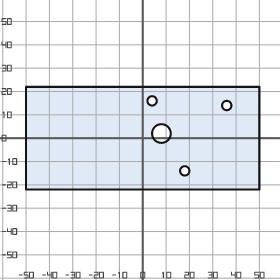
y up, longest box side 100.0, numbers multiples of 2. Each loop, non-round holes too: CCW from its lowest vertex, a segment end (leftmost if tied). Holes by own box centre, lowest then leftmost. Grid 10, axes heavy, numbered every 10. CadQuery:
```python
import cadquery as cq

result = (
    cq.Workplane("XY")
    .moveTo(-50.0, -22.0)
    .lineTo(50.0, -22.0)
    .lineTo(50.0, 22.0)
    .lineTo(-50.0, 22.0)
    .close()
    .moveTo(18.0, -14.0)
    .circle(2.0)
    .moveTo(8.0, 2.0)
    .circle(4.0)
    .moveTo(36.0, 14.0)
    .circle(2.0)
    .moveTo(4.0, 16.0)
    .circle(2.0)
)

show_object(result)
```